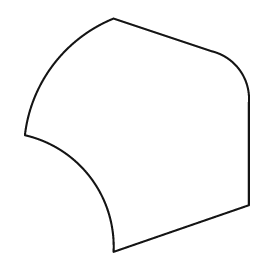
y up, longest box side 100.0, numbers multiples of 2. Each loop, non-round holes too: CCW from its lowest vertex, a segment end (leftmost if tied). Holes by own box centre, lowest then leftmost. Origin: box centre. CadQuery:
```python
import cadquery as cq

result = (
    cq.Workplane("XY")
    .moveTo(-10.0, -50.0)
    .lineTo(48.0, -30.0)
    .lineTo(48.0, 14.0)
    .threePointArc((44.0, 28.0), (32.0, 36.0))
    .lineTo(-10.0, 50.0)
    .threePointArc((-36.0, 30.0), (-48.0, 0.0))
    .threePointArc((-20.0, -18.0), (-10.0, -50.0))
    .close()
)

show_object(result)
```